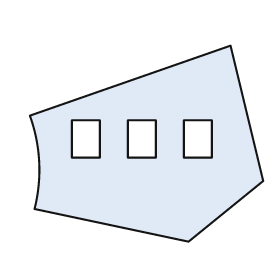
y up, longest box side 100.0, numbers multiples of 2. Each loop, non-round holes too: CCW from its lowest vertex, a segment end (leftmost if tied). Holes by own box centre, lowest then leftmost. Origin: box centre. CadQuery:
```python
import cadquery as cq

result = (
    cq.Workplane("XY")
    .moveTo(18.0, -42.0)
    .lineTo(50.0, -16.0)
    .lineTo(36.0, 42.0)
    .lineTo(-50.0, 12.0)
    .threePointArc((-46.0, -8.0), (-48.0, -28.0))
    .close()
    .moveTo(-32.0, -6.0)
    .lineTo(-20.0, -6.0)
    .lineTo(-20.0, 10.0)
    .lineTo(-32.0, 10.0)
    .close()
    .moveTo(-8.0, -6.0)
    .lineTo(4.0, -6.0)
    .lineTo(4.0, 10.0)
    .lineTo(-8.0, 10.0)
    .close()
    .moveTo(16.0, -6.0)
    .lineTo(28.0, -6.0)
    .lineTo(28.0, 10.0)
    .lineTo(16.0, 10.0)
    .close()
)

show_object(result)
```